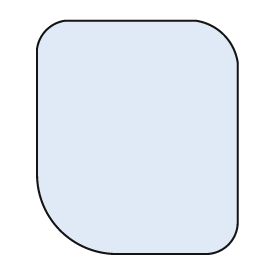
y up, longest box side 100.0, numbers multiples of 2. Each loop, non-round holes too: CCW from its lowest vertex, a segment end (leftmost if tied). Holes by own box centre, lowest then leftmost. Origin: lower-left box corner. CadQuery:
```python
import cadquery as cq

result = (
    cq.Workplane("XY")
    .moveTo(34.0, 0.0)
    .lineTo(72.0, 0.0)
    .threePointArc((82.0, 4.0), (86.0, 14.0))
    .lineTo(86.0, 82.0)
    .threePointArc((80.0, 94.0), (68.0, 100.0))
    .lineTo(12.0, 100.0)
    .threePointArc((4.0, 96.0), (0.0, 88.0))
    .lineTo(0.0, 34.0)
    .threePointArc((10.0, 10.0), (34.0, 0.0))
    .close()
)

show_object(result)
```